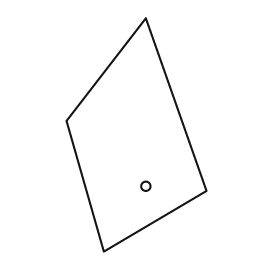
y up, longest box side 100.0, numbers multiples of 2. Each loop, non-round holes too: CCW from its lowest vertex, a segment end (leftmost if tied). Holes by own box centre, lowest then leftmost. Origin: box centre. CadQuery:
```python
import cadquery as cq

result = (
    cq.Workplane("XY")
    .moveTo(-14.0, -50.0)
    .lineTo(30.0, -24.0)
    .lineTo(4.0, 50.0)
    .lineTo(-30.0, 6.0)
    .close()
    .moveTo(4.0, -22.0)
    .circle(2.0)
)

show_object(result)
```